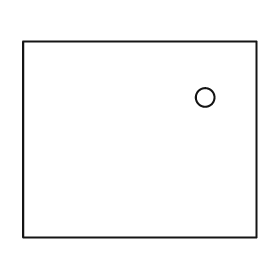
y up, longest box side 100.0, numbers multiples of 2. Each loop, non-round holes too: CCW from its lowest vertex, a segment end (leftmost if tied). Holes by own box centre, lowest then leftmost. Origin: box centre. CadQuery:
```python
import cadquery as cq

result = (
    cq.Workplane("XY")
    .moveTo(-50.0, -42.0)
    .lineTo(50.0, -42.0)
    .lineTo(50.0, 42.0)
    .lineTo(-50.0, 42.0)
    .close()
    .moveTo(28.0, 18.0)
    .circle(4.0)
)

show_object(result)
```